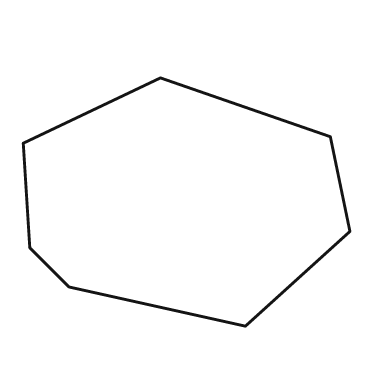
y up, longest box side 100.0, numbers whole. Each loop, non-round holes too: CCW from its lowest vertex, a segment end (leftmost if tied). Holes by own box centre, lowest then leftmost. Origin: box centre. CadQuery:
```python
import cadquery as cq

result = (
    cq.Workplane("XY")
    .moveTo(18.0, -38.0)
    .lineTo(50.0, -9.0)
    .lineTo(44.0, 20.0)
    .lineTo(-8.0, 38.0)
    .lineTo(-50.0, 18.0)
    .lineTo(-48.0, -14.0)
    .lineTo(-36.0, -26.0)
    .close()
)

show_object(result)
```